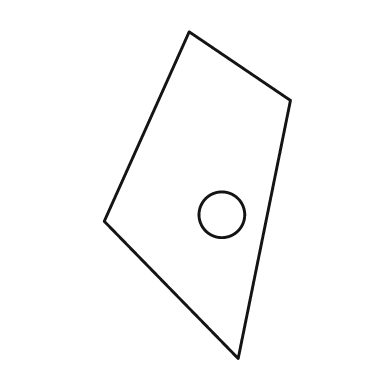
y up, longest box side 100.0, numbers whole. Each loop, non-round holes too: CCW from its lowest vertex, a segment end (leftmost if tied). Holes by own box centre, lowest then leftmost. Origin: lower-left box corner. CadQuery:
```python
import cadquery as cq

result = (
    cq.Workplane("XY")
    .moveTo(41.0, 0.0)
    .lineTo(57.0, 79.0)
    .lineTo(26.0, 100.0)
    .lineTo(0.0, 42.0)
    .close()
    .moveTo(36.0, 44.0)
    .circle(7.0)
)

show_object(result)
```